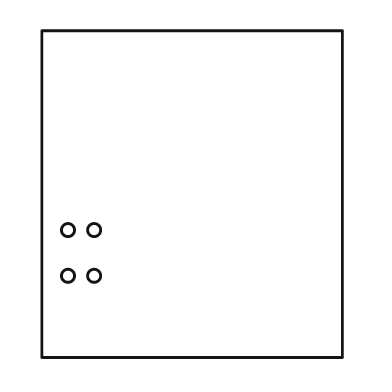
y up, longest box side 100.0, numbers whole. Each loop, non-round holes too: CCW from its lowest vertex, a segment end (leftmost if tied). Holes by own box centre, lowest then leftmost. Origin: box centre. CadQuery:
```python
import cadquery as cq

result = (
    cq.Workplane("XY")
    .moveTo(-46.0, -50.0)
    .lineTo(46.0, -50.0)
    .lineTo(46.0, 50.0)
    .lineTo(-46.0, 50.0)
    .close()
    .moveTo(-38.0, -25.0)
    .circle(2.0)
    .moveTo(-30.0, -25.0)
    .circle(2.0)
    .moveTo(-38.0, -11.0)
    .circle(2.0)
    .moveTo(-30.0, -11.0)
    .circle(2.0)
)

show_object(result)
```